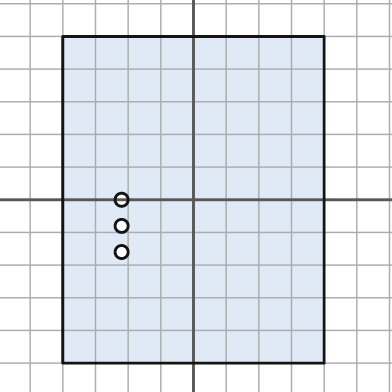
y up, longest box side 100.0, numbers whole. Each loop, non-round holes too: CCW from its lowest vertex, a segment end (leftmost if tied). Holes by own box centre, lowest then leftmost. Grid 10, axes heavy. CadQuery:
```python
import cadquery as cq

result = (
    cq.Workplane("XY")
    .moveTo(-40.0, -50.0)
    .lineTo(40.0, -50.0)
    .lineTo(40.0, 50.0)
    .lineTo(-40.0, 50.0)
    .close()
    .moveTo(-22.0, -16.0)
    .circle(2.0)
    .moveTo(-22.0, -8.0)
    .circle(2.0)
    .moveTo(-22.0, 0.0)
    .circle(2.0)
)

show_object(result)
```